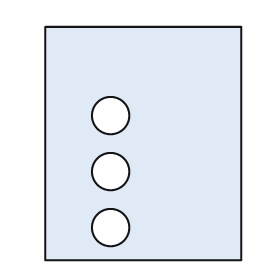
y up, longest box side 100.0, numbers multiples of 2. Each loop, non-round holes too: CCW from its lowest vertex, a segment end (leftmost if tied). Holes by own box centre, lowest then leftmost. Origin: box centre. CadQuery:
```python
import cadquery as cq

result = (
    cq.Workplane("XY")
    .moveTo(-42.0, -50.0)
    .lineTo(42.0, -50.0)
    .lineTo(42.0, 50.0)
    .lineTo(-42.0, 50.0)
    .close()
    .moveTo(-14.0, -36.0)
    .circle(8.0)
    .moveTo(-14.0, -12.0)
    .circle(8.0)
    .moveTo(-14.0, 12.0)
    .circle(8.0)
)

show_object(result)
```